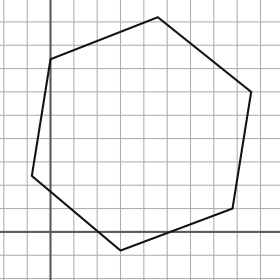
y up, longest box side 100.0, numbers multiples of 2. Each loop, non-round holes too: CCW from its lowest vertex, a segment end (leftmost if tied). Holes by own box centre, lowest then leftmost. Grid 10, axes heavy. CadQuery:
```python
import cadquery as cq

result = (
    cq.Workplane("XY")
    .moveTo(30.0, -8.0)
    .lineTo(78.0, 10.0)
    .lineTo(86.0, 60.0)
    .lineTo(46.0, 92.0)
    .lineTo(0.0, 74.0)
    .lineTo(-8.0, 24.0)
    .close()
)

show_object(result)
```